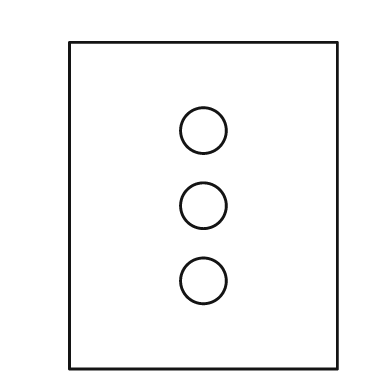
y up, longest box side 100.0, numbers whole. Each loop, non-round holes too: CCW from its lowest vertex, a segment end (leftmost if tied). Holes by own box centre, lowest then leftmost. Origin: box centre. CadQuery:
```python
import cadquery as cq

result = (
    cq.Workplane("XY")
    .moveTo(-41.0, -50.0)
    .lineTo(41.0, -50.0)
    .lineTo(41.0, 50.0)
    .lineTo(-41.0, 50.0)
    .close()
    .moveTo(0.0, -23.0)
    .circle(7.0)
    .moveTo(0.0, 0.0)
    .circle(7.0)
    .moveTo(0.0, 23.0)
    .circle(7.0)
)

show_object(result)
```